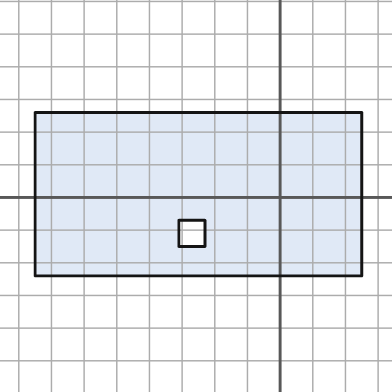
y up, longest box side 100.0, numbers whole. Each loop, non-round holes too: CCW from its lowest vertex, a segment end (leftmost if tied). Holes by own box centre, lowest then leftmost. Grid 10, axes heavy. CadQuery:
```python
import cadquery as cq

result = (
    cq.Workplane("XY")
    .moveTo(-75.0, -24.0)
    .lineTo(25.0, -24.0)
    .lineTo(25.0, 26.0)
    .lineTo(-75.0, 26.0)
    .close()
    .moveTo(-31.0, -15.0)
    .lineTo(-23.0, -15.0)
    .lineTo(-23.0, -7.0)
    .lineTo(-31.0, -7.0)
    .close()
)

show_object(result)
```